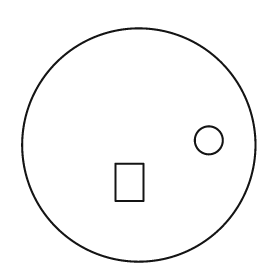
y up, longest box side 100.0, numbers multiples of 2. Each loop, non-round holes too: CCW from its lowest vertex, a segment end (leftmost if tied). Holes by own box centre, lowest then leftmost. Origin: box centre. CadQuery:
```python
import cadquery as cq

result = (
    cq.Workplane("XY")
    .moveTo(0.0, 0.0)
    .circle(50.0)
    .moveTo(-10.0, -24.0)
    .lineTo(2.0, -24.0)
    .lineTo(2.0, -8.0)
    .lineTo(-10.0, -8.0)
    .close()
    .moveTo(30.0, 2.0)
    .circle(6.0)
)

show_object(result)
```